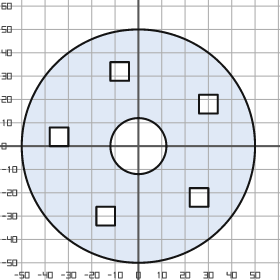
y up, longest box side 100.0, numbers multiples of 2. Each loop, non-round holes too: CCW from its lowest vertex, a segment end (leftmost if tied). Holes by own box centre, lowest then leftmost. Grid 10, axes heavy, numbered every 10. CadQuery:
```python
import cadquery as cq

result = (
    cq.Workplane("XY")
    .moveTo(0.0, 0.0)
    .circle(50.0)
    .moveTo(-18.0, -34.0)
    .lineTo(-10.0, -34.0)
    .lineTo(-10.0, -26.0)
    .lineTo(-18.0, -26.0)
    .close()
    .moveTo(22.0, -26.0)
    .lineTo(30.0, -26.0)
    .lineTo(30.0, -18.0)
    .lineTo(22.0, -18.0)
    .close()
    .moveTo(0.0, 0.0)
    .circle(12.0)
    .moveTo(-38.0, 0.0)
    .lineTo(-30.0, 0.0)
    .lineTo(-30.0, 8.0)
    .lineTo(-38.0, 8.0)
    .close()
    .moveTo(26.0, 14.0)
    .lineTo(34.0, 14.0)
    .lineTo(34.0, 22.0)
    .lineTo(26.0, 22.0)
    .close()
    .moveTo(-12.0, 28.0)
    .lineTo(-4.0, 28.0)
    .lineTo(-4.0, 36.0)
    .lineTo(-12.0, 36.0)
    .close()
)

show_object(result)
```